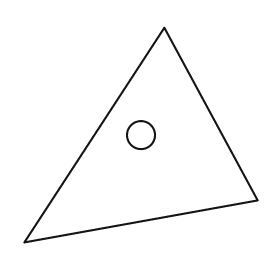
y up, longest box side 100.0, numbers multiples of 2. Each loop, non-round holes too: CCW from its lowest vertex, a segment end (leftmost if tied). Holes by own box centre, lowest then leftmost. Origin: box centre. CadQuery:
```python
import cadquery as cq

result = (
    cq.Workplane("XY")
    .moveTo(-50.0, -46.0)
    .lineTo(50.0, -28.0)
    .lineTo(10.0, 46.0)
    .close()
    .moveTo(0.0, 0.0)
    .circle(6.0)
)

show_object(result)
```